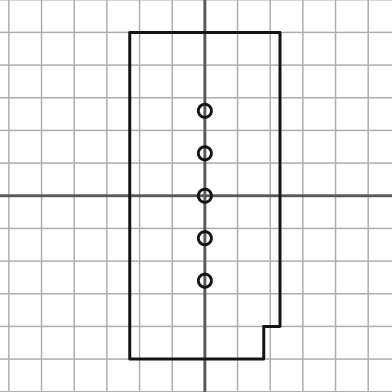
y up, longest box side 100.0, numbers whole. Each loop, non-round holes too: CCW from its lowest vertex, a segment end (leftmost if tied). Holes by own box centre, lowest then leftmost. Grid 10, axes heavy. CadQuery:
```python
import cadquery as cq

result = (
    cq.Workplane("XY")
    .moveTo(-23.0, -50.0)
    .lineTo(18.0, -50.0)
    .lineTo(18.0, -40.0)
    .lineTo(23.0, -40.0)
    .lineTo(23.0, 50.0)
    .lineTo(-23.0, 50.0)
    .close()
    .moveTo(0.0, -26.0)
    .circle(2.0)
    .moveTo(0.0, -13.0)
    .circle(2.0)
    .moveTo(0.0, 0.0)
    .circle(2.0)
    .moveTo(0.0, 13.0)
    .circle(2.0)
    .moveTo(0.0, 26.0)
    .circle(2.0)
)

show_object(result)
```